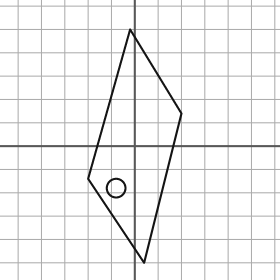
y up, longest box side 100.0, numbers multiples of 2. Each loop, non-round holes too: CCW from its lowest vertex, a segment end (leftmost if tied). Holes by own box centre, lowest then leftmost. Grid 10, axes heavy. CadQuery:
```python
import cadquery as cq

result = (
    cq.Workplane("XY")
    .moveTo(4.0, -50.0)
    .lineTo(20.0, 14.0)
    .lineTo(-2.0, 50.0)
    .lineTo(-20.0, -14.0)
    .close()
    .moveTo(-8.0, -18.0)
    .circle(4.0)
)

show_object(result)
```